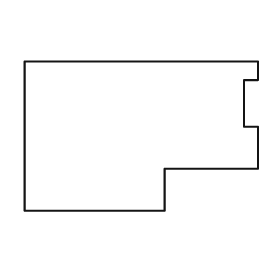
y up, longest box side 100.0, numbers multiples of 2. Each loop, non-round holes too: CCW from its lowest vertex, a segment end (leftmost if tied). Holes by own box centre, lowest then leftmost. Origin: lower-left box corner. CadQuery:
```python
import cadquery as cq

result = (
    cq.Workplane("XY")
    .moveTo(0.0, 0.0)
    .lineTo(60.0, 0.0)
    .lineTo(60.0, 18.0)
    .lineTo(100.0, 18.0)
    .lineTo(100.0, 36.0)
    .lineTo(94.0, 36.0)
    .lineTo(94.0, 56.0)
    .lineTo(100.0, 56.0)
    .lineTo(100.0, 64.0)
    .lineTo(0.0, 64.0)
    .close()
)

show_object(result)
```